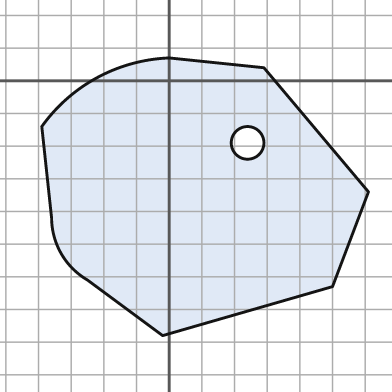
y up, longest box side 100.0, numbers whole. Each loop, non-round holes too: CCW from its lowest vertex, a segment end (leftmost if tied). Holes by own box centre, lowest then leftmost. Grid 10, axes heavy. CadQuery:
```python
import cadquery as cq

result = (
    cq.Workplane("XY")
    .moveTo(-2.0, -78.0)
    .lineTo(50.0, -63.0)
    .lineTo(61.0, -34.0)
    .lineTo(29.0, 4.0)
    .lineTo(0.0, 7.0)
    .threePointArc((-22.0, 1.0), (-39.0, -14.0))
    .lineTo(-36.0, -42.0)
    .threePointArc((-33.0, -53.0), (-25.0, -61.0))
    .close()
    .moveTo(24.0, -19.0)
    .circle(5.0)
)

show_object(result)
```